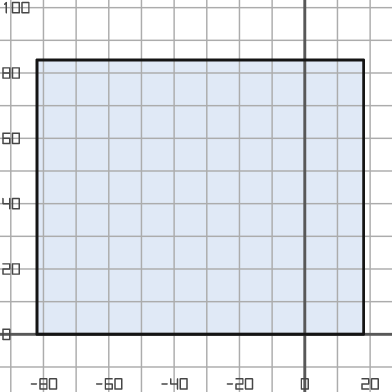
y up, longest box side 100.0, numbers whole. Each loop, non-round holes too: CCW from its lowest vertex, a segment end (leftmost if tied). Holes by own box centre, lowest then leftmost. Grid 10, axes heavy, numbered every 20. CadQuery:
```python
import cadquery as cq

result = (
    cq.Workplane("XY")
    .moveTo(-82.0, 0.0)
    .lineTo(18.0, 0.0)
    .lineTo(18.0, 84.0)
    .lineTo(-82.0, 84.0)
    .close()
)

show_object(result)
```